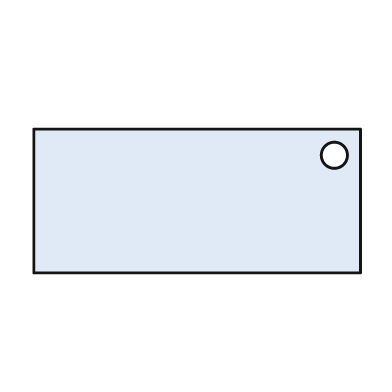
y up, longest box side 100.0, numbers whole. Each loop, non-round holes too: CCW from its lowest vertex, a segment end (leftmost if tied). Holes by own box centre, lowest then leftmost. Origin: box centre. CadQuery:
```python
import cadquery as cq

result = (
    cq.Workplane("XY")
    .moveTo(-50.0, -22.0)
    .lineTo(50.0, -22.0)
    .lineTo(50.0, 22.0)
    .lineTo(-50.0, 22.0)
    .close()
    .moveTo(42.0, 14.0)
    .circle(4.0)
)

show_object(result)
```